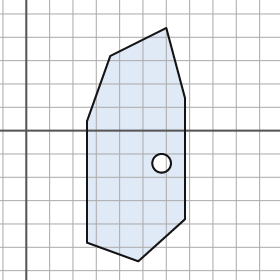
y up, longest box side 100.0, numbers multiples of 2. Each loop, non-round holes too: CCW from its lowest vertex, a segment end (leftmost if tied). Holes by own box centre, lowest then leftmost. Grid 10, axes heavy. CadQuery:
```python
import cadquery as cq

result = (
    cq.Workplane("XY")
    .moveTo(48.0, -56.0)
    .lineTo(68.0, -38.0)
    .lineTo(68.0, 14.0)
    .lineTo(60.0, 44.0)
    .lineTo(36.0, 32.0)
    .lineTo(26.0, 4.0)
    .lineTo(26.0, -48.0)
    .close()
    .moveTo(58.0, -14.0)
    .circle(4.0)
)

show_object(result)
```